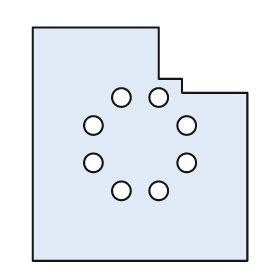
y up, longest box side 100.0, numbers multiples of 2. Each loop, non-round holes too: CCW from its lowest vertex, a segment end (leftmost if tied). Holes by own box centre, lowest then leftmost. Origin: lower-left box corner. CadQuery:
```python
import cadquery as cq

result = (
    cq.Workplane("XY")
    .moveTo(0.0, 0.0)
    .lineTo(92.0, 0.0)
    .lineTo(92.0, 72.0)
    .lineTo(64.0, 72.0)
    .lineTo(64.0, 78.0)
    .lineTo(54.0, 78.0)
    .lineTo(54.0, 100.0)
    .lineTo(0.0, 100.0)
    .close()
    .moveTo(38.0, 30.0)
    .circle(4.0)
    .moveTo(54.0, 30.0)
    .circle(4.0)
    .moveTo(26.0, 42.0)
    .circle(4.0)
    .moveTo(66.0, 42.0)
    .circle(4.0)
    .moveTo(26.0, 58.0)
    .circle(4.0)
    .moveTo(66.0, 58.0)
    .circle(4.0)
    .moveTo(38.0, 70.0)
    .circle(4.0)
    .moveTo(54.0, 70.0)
    .circle(4.0)
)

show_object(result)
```